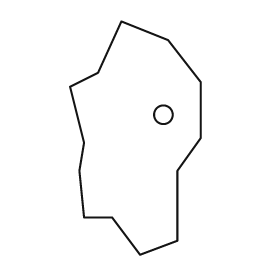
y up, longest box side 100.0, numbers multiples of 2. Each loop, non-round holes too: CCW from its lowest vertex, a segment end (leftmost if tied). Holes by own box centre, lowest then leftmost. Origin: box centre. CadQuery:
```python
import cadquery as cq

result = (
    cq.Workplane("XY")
    .moveTo(2.0, -50.0)
    .lineTo(18.0, -44.0)
    .lineTo(18.0, -14.0)
    .lineTo(28.0, 0.0)
    .lineTo(28.0, 24.0)
    .lineTo(14.0, 42.0)
    .lineTo(-6.0, 50.0)
    .lineTo(-16.0, 28.0)
    .lineTo(-28.0, 22.0)
    .lineTo(-22.0, -2.0)
    .lineTo(-24.0, -14.0)
    .lineTo(-22.0, -34.0)
    .lineTo(-10.0, -34.0)
    .close()
    .moveTo(12.0, 10.0)
    .circle(4.0)
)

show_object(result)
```